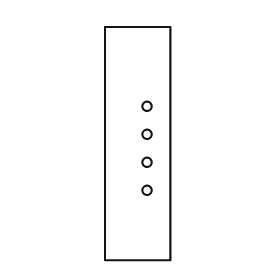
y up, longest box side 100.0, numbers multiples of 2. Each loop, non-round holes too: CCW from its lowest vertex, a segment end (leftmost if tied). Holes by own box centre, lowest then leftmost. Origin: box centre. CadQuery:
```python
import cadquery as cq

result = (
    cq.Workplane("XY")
    .moveTo(-14.0, -50.0)
    .lineTo(14.0, -50.0)
    .lineTo(14.0, 50.0)
    .lineTo(-14.0, 50.0)
    .close()
    .moveTo(4.0, -20.0)
    .circle(2.0)
    .moveTo(4.0, -8.0)
    .circle(2.0)
    .moveTo(4.0, 4.0)
    .circle(2.0)
    .moveTo(4.0, 16.0)
    .circle(2.0)
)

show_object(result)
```